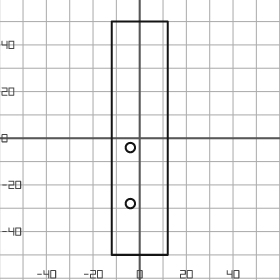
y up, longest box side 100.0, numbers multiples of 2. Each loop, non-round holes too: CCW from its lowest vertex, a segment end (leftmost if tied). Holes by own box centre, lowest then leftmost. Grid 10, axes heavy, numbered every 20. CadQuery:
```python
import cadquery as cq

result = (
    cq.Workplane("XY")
    .moveTo(-12.0, -50.0)
    .lineTo(12.0, -50.0)
    .lineTo(12.0, 50.0)
    .lineTo(-12.0, 50.0)
    .close()
    .moveTo(-4.0, -28.0)
    .circle(2.0)
    .moveTo(-4.0, -4.0)
    .circle(2.0)
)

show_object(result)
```